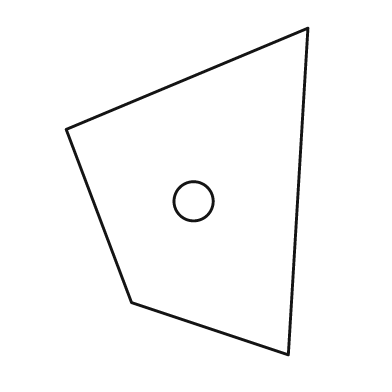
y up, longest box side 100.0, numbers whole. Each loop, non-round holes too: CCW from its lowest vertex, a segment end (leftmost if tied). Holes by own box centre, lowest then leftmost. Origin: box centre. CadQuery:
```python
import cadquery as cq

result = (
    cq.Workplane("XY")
    .moveTo(31.0, -50.0)
    .lineTo(37.0, 50.0)
    .lineTo(-37.0, 19.0)
    .lineTo(-17.0, -34.0)
    .close()
    .moveTo(2.0, -3.0)
    .circle(6.0)
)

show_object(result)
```